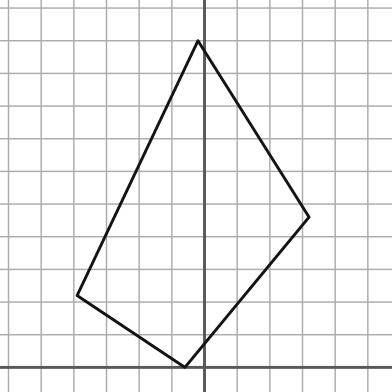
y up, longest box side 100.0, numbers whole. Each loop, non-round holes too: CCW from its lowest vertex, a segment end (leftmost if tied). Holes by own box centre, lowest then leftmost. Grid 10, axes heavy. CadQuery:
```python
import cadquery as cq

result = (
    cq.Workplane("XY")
    .moveTo(-6.0, 0.0)
    .lineTo(32.0, 46.0)
    .lineTo(-2.0, 100.0)
    .lineTo(-39.0, 22.0)
    .close()
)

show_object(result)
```